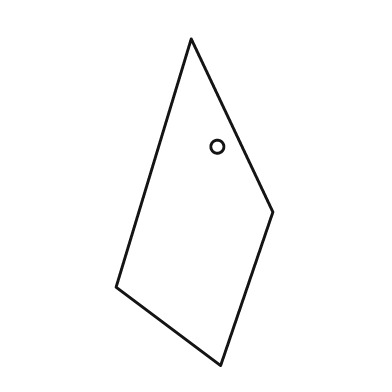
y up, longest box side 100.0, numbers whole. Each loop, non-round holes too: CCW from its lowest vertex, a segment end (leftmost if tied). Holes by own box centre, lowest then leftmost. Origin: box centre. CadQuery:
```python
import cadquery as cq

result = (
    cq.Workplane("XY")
    .moveTo(8.0, -50.0)
    .lineTo(24.0, -3.0)
    .lineTo(-1.0, 50.0)
    .lineTo(-24.0, -26.0)
    .close()
    .moveTo(7.0, 17.0)
    .circle(2.0)
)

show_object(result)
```